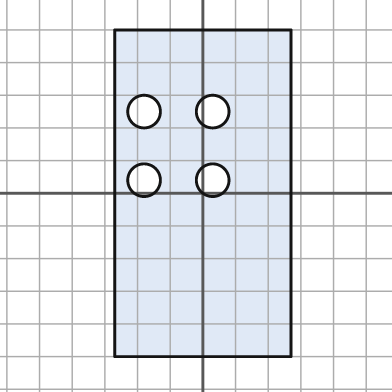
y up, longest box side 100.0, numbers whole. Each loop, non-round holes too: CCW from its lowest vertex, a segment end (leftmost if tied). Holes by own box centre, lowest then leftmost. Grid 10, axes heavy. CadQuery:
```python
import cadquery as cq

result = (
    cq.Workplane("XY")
    .moveTo(-27.0, -50.0)
    .lineTo(27.0, -50.0)
    .lineTo(27.0, 50.0)
    .lineTo(-27.0, 50.0)
    .close()
    .moveTo(-18.0, 4.0)
    .circle(5.0)
    .moveTo(3.0, 4.0)
    .circle(5.0)
    .moveTo(-18.0, 25.0)
    .circle(5.0)
    .moveTo(3.0, 25.0)
    .circle(5.0)
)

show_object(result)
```